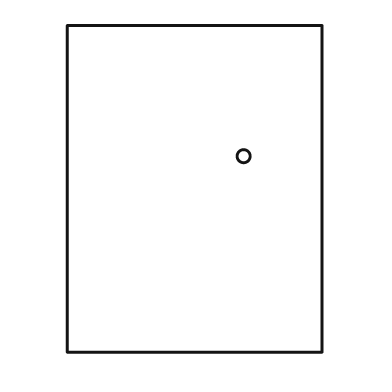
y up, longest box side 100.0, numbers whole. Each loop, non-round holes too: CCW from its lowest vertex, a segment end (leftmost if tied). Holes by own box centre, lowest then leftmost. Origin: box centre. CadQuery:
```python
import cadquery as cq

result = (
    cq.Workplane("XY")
    .moveTo(-39.0, -50.0)
    .lineTo(39.0, -50.0)
    .lineTo(39.0, 50.0)
    .lineTo(-39.0, 50.0)
    .close()
    .moveTo(15.0, 10.0)
    .circle(2.0)
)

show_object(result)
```